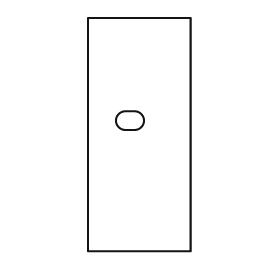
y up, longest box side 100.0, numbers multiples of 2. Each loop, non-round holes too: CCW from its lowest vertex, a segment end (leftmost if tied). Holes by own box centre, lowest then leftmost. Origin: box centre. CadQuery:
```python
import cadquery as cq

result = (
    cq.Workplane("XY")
    .moveTo(-22.0, -50.0)
    .lineTo(22.0, -50.0)
    .lineTo(22.0, 50.0)
    .lineTo(-22.0, 50.0)
    .close()
    .moveTo(-6.0, 2.0)
    .lineTo(-2.0, 2.0)
    .threePointArc((2.0, 6.0), (-2.0, 10.0))
    .lineTo(-6.0, 10.0)
    .threePointArc((-10.0, 6.0), (-6.0, 2.0))
    .close()
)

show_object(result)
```